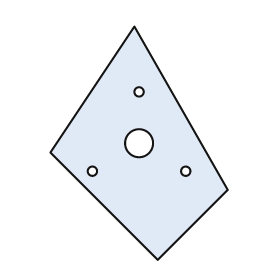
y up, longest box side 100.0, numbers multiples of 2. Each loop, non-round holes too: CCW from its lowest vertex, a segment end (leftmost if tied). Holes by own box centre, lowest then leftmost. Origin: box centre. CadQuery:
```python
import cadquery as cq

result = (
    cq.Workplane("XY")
    .moveTo(8.0, -50.0)
    .lineTo(38.0, -20.0)
    .lineTo(-2.0, 50.0)
    .lineTo(-38.0, -4.0)
    .close()
    .moveTo(-20.0, -12.0)
    .circle(2.0)
    .moveTo(20.0, -12.0)
    .circle(2.0)
    .moveTo(0.0, 0.0)
    .circle(6.0)
    .moveTo(0.0, 22.0)
    .circle(2.0)
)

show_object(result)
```